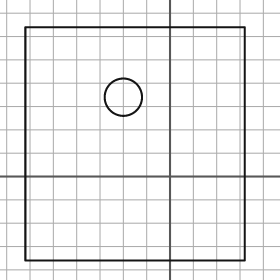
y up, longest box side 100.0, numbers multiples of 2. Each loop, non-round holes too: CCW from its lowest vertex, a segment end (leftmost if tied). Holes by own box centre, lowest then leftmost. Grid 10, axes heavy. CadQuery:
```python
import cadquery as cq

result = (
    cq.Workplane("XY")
    .moveTo(-62.0, -36.0)
    .lineTo(32.0, -36.0)
    .lineTo(32.0, 64.0)
    .lineTo(-62.0, 64.0)
    .close()
    .moveTo(-20.0, 34.0)
    .circle(8.0)
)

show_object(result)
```